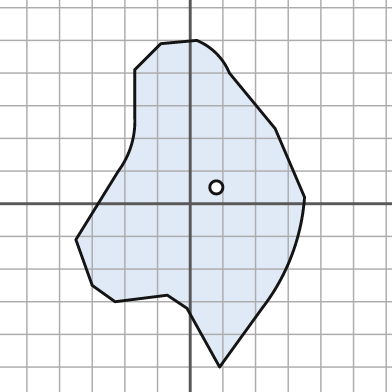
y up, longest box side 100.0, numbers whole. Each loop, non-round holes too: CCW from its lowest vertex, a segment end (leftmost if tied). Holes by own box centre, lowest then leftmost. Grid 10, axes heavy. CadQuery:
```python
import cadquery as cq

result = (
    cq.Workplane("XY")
    .moveTo(9.0, -50.0)
    .lineTo(22.0, -32.0)
    .threePointArc((31.0, -16.0), (35.0, 2.0))
    .lineTo(26.0, 23.0)
    .lineTo(12.0, 40.0)
    .threePointArc((8.0, 46.0), (2.0, 50.0))
    .lineTo(-9.0, 49.0)
    .lineTo(-17.0, 41.0)
    .lineTo(-17.0, 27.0)
    .threePointArc((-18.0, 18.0), (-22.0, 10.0))
    .lineTo(-35.0, -11.0)
    .lineTo(-30.0, -25.0)
    .lineTo(-23.0, -30.0)
    .lineTo(-7.0, -28.0)
    .lineTo(-1.0, -32.0)
    .close()
    .moveTo(8.0, 5.0)
    .circle(2.0)
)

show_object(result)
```